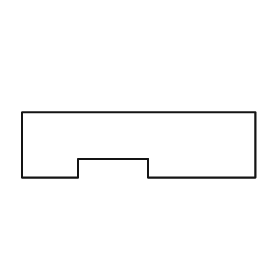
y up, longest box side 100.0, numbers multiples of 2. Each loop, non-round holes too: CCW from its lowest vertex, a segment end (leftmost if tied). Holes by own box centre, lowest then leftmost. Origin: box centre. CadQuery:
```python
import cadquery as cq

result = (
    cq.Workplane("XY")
    .moveTo(-50.0, -14.0)
    .lineTo(-26.0, -14.0)
    .lineTo(-26.0, -6.0)
    .lineTo(4.0, -6.0)
    .lineTo(4.0, -14.0)
    .lineTo(50.0, -14.0)
    .lineTo(50.0, 14.0)
    .lineTo(-50.0, 14.0)
    .close()
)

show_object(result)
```